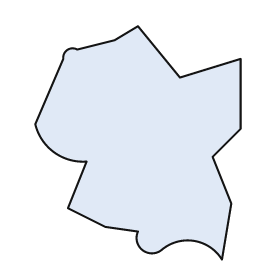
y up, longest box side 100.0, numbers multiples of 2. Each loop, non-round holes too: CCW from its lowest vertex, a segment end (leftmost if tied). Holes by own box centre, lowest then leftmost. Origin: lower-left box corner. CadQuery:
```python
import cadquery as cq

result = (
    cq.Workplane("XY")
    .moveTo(80.0, 0.0)
    .lineTo(84.0, 24.0)
    .lineTo(76.0, 44.0)
    .lineTo(88.0, 56.0)
    .lineTo(88.0, 86.0)
    .lineTo(62.0, 78.0)
    .lineTo(44.0, 100.0)
    .lineTo(34.0, 94.0)
    .lineTo(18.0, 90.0)
    .threePointArc((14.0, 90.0), (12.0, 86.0))
    .lineTo(0.0, 58.0)
    .threePointArc((8.0, 46.0), (22.0, 42.0))
    .lineTo(14.0, 22.0)
    .lineTo(30.0, 14.0)
    .lineTo(44.0, 12.0)
    .threePointArc((46.0, 4.0), (54.0, 4.0))
    .threePointArc((68.0, 8.0), (80.0, 0.0))
    .close()
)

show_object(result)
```